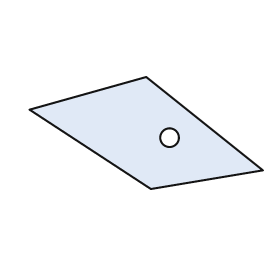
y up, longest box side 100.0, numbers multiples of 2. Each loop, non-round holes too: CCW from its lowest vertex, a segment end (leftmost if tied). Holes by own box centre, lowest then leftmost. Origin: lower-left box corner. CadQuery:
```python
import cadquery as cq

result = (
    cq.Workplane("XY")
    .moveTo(52.0, 0.0)
    .lineTo(100.0, 8.0)
    .lineTo(50.0, 48.0)
    .lineTo(0.0, 34.0)
    .close()
    .moveTo(60.0, 22.0)
    .circle(4.0)
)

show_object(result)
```